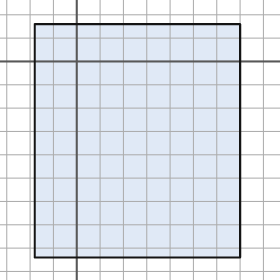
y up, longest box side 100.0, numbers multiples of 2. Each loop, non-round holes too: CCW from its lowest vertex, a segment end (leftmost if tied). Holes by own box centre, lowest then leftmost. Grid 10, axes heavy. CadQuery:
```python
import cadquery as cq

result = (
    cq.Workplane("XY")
    .moveTo(-18.0, -84.0)
    .lineTo(70.0, -84.0)
    .lineTo(70.0, 16.0)
    .lineTo(-18.0, 16.0)
    .close()
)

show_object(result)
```